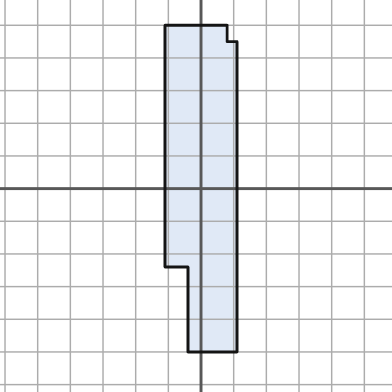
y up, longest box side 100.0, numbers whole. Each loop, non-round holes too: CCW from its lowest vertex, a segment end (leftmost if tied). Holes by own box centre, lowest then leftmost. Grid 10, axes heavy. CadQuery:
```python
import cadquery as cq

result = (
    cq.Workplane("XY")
    .moveTo(-4.0, -50.0)
    .lineTo(11.0, -50.0)
    .lineTo(11.0, 45.0)
    .lineTo(8.0, 45.0)
    .lineTo(8.0, 50.0)
    .lineTo(-11.0, 50.0)
    .lineTo(-11.0, -24.0)
    .lineTo(-4.0, -24.0)
    .close()
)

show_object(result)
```